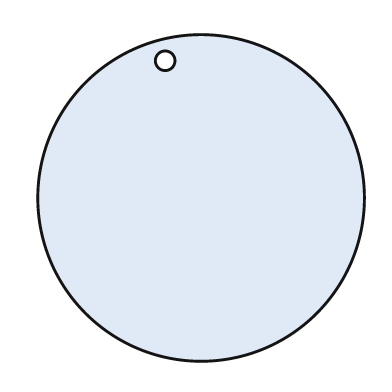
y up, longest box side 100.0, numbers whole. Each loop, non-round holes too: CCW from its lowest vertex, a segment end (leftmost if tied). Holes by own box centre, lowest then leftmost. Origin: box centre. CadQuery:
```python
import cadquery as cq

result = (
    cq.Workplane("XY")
    .moveTo(0.0, 0.0)
    .circle(50.0)
    .moveTo(-11.0, 42.0)
    .circle(3.0)
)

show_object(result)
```